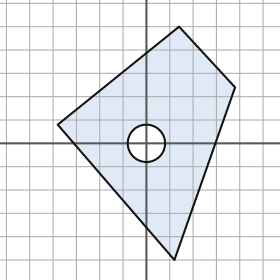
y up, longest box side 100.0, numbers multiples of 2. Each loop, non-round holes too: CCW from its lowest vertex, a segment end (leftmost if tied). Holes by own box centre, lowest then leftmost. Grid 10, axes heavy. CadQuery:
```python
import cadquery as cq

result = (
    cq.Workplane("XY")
    .moveTo(12.0, -50.0)
    .lineTo(38.0, 24.0)
    .lineTo(14.0, 50.0)
    .lineTo(-38.0, 8.0)
    .close()
    .moveTo(0.0, 0.0)
    .circle(8.0)
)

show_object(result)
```